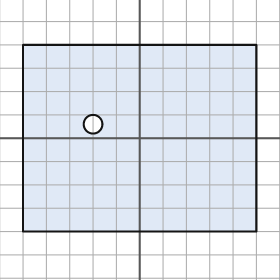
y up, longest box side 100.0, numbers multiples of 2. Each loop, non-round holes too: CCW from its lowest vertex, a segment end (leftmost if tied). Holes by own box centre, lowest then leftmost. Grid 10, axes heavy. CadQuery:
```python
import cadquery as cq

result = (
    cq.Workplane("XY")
    .moveTo(-50.0, -40.0)
    .lineTo(50.0, -40.0)
    .lineTo(50.0, 40.0)
    .lineTo(-50.0, 40.0)
    .close()
    .moveTo(-20.0, 6.0)
    .circle(4.0)
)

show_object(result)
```